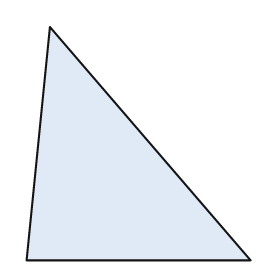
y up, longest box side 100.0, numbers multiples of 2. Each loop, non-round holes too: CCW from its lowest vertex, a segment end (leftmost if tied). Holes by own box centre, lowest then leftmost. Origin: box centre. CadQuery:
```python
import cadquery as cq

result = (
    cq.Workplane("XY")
    .moveTo(-48.0, -50.0)
    .lineTo(48.0, -50.0)
    .lineTo(-38.0, 50.0)
    .close()
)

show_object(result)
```